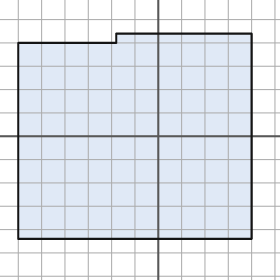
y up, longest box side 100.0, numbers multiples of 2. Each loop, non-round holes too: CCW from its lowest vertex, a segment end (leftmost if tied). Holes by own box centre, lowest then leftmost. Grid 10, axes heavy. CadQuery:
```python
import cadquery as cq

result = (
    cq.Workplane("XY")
    .moveTo(-60.0, -44.0)
    .lineTo(40.0, -44.0)
    .lineTo(40.0, 44.0)
    .lineTo(-18.0, 44.0)
    .lineTo(-18.0, 40.0)
    .lineTo(-60.0, 40.0)
    .close()
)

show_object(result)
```